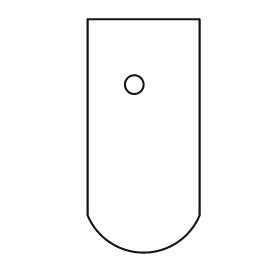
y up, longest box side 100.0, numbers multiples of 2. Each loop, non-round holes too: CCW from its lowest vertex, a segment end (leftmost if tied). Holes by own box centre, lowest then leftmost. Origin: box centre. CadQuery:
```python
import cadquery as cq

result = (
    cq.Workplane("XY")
    .moveTo(-24.0, -34.0)
    .threePointArc((0.0, -50.0), (24.0, -34.0))
    .lineTo(24.0, 50.0)
    .lineTo(-24.0, 50.0)
    .close()
    .moveTo(-4.0, 22.0)
    .circle(4.0)
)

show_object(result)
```